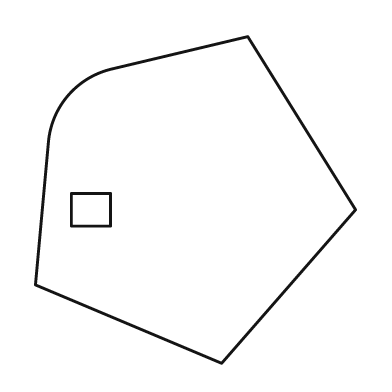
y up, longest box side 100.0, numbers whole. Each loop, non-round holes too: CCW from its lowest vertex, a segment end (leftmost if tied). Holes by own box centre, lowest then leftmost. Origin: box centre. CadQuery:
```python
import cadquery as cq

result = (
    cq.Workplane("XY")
    .moveTo(8.0, -50.0)
    .lineTo(49.0, -3.0)
    .lineTo(16.0, 50.0)
    .lineTo(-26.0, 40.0)
    .threePointArc((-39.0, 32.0), (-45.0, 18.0))
    .lineTo(-49.0, -26.0)
    .close()
    .moveTo(-38.0, -8.0)
    .lineTo(-26.0, -8.0)
    .lineTo(-26.0, 2.0)
    .lineTo(-38.0, 2.0)
    .close()
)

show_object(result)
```